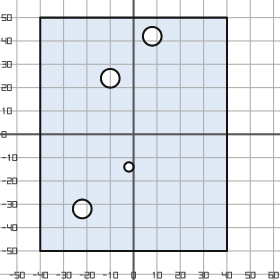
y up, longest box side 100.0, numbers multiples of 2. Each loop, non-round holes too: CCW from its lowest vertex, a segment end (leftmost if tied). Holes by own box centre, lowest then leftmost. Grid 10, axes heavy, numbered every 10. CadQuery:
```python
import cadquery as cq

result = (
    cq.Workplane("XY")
    .moveTo(-40.0, -50.0)
    .lineTo(40.0, -50.0)
    .lineTo(40.0, 50.0)
    .lineTo(-40.0, 50.0)
    .close()
    .moveTo(-22.0, -32.0)
    .circle(4.0)
    .moveTo(-2.0, -14.0)
    .circle(2.0)
    .moveTo(-10.0, 24.0)
    .circle(4.0)
    .moveTo(8.0, 42.0)
    .circle(4.0)
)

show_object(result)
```